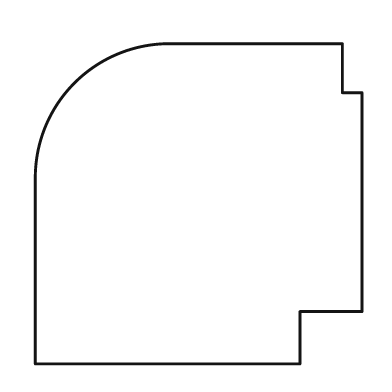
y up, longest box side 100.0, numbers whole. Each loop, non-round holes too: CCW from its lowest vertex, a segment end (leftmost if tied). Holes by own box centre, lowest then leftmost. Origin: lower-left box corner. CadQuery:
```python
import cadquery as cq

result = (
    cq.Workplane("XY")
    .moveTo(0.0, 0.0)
    .lineTo(81.0, 0.0)
    .lineTo(81.0, 16.0)
    .lineTo(100.0, 16.0)
    .lineTo(100.0, 83.0)
    .lineTo(94.0, 83.0)
    .lineTo(94.0, 98.0)
    .lineTo(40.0, 98.0)
    .threePointArc((12.0, 86.0), (0.0, 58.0))
    .close()
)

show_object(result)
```